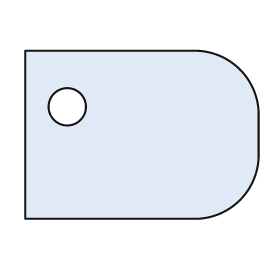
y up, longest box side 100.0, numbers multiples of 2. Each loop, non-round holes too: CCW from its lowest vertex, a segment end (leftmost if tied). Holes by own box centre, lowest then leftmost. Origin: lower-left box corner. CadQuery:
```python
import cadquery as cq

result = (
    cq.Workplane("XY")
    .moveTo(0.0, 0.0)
    .lineTo(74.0, 0.0)
    .threePointArc((92.0, 8.0), (100.0, 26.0))
    .lineTo(100.0, 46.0)
    .threePointArc((92.0, 64.0), (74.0, 72.0))
    .lineTo(0.0, 72.0)
    .close()
    .moveTo(18.0, 48.0)
    .circle(8.0)
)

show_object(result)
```